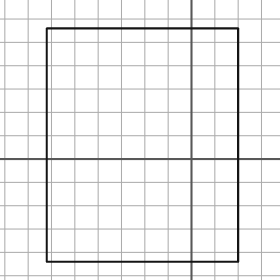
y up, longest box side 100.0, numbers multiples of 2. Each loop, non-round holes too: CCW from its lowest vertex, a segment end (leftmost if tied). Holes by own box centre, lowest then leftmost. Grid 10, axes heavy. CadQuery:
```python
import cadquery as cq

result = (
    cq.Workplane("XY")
    .moveTo(-62.0, -44.0)
    .lineTo(20.0, -44.0)
    .lineTo(20.0, 56.0)
    .lineTo(-62.0, 56.0)
    .close()
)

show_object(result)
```